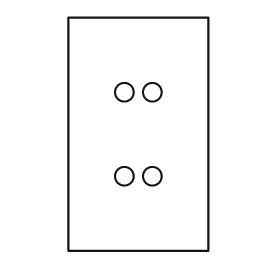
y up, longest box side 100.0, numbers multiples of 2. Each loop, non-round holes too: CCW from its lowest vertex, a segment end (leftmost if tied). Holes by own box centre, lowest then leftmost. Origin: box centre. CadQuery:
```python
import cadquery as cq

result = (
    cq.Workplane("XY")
    .moveTo(-30.0, -50.0)
    .lineTo(30.0, -50.0)
    .lineTo(30.0, 50.0)
    .lineTo(-30.0, 50.0)
    .close()
    .moveTo(-6.0, -18.0)
    .circle(4.0)
    .moveTo(6.0, -18.0)
    .circle(4.0)
    .moveTo(-6.0, 18.0)
    .circle(4.0)
    .moveTo(6.0, 18.0)
    .circle(4.0)
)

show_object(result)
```